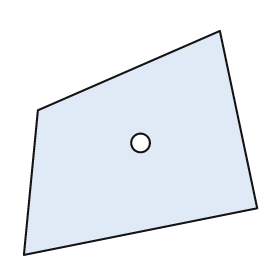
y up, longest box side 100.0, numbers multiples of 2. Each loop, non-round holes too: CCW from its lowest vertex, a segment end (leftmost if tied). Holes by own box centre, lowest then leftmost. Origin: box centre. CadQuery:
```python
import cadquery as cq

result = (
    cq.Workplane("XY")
    .moveTo(-50.0, -48.0)
    .lineTo(50.0, -28.0)
    .lineTo(34.0, 48.0)
    .lineTo(-44.0, 14.0)
    .close()
    .moveTo(0.0, 0.0)
    .circle(4.0)
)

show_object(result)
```